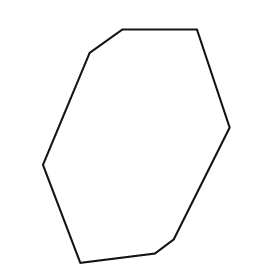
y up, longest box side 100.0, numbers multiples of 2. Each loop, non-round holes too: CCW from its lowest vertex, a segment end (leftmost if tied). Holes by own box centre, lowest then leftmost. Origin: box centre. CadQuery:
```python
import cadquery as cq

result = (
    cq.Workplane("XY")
    .moveTo(-24.0, -50.0)
    .lineTo(8.0, -46.0)
    .lineTo(16.0, -40.0)
    .lineTo(40.0, 8.0)
    .lineTo(26.0, 50.0)
    .lineTo(-6.0, 50.0)
    .lineTo(-20.0, 40.0)
    .lineTo(-40.0, -8.0)
    .close()
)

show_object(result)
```